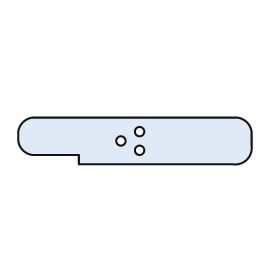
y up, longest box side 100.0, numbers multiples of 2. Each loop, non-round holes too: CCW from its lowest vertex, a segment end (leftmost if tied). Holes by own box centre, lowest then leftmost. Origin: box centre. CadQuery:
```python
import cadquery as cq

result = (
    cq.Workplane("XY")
    .moveTo(-24.0, -10.0)
    .lineTo(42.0, -10.0)
    .threePointArc((48.0, -8.0), (50.0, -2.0))
    .lineTo(50.0, 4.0)
    .threePointArc((48.0, 8.0), (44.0, 10.0))
    .lineTo(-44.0, 10.0)
    .threePointArc((-48.0, 8.0), (-50.0, 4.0))
    .lineTo(-50.0, 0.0)
    .threePointArc((-48.0, -4.0), (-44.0, -6.0))
    .lineTo(-24.0, -6.0)
    .close()
    .moveTo(2.0, -4.0)
    .circle(2.0)
    .moveTo(-6.0, 0.0)
    .circle(2.0)
    .moveTo(2.0, 4.0)
    .circle(2.0)
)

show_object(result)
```